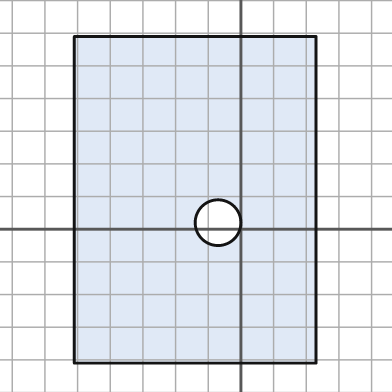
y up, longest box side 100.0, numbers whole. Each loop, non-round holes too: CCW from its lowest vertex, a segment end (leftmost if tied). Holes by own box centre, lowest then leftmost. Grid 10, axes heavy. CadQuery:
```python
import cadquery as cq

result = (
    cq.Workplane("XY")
    .moveTo(-51.0, -41.0)
    .lineTo(23.0, -41.0)
    .lineTo(23.0, 59.0)
    .lineTo(-51.0, 59.0)
    .close()
    .moveTo(-7.0, 2.0)
    .circle(7.0)
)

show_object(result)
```